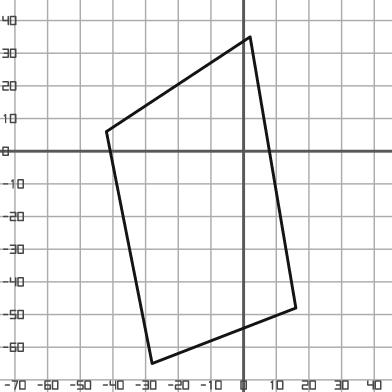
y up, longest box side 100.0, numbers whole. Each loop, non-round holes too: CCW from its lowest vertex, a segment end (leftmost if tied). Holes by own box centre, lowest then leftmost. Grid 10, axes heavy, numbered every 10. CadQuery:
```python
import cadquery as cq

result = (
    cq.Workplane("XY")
    .moveTo(-28.0, -65.0)
    .lineTo(16.0, -48.0)
    .lineTo(2.0, 35.0)
    .lineTo(-42.0, 6.0)
    .close()
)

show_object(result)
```